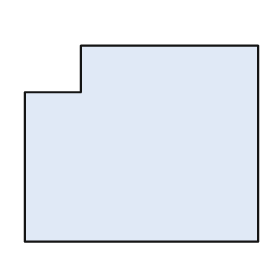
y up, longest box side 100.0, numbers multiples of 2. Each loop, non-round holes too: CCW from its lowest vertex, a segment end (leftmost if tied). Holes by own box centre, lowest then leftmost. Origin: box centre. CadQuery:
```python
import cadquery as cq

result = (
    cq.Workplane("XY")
    .moveTo(-50.0, -42.0)
    .lineTo(50.0, -42.0)
    .lineTo(50.0, 42.0)
    .lineTo(-26.0, 42.0)
    .lineTo(-26.0, 22.0)
    .lineTo(-50.0, 22.0)
    .close()
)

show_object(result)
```